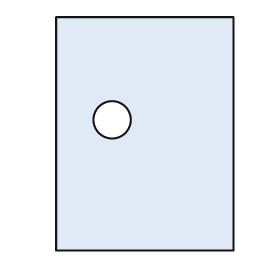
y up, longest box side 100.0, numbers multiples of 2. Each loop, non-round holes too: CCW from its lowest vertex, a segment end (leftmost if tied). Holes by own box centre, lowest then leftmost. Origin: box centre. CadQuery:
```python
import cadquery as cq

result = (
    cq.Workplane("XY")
    .moveTo(-38.0, -50.0)
    .lineTo(38.0, -50.0)
    .lineTo(38.0, 50.0)
    .lineTo(-38.0, 50.0)
    .close()
    .moveTo(-14.0, 6.0)
    .circle(8.0)
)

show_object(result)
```